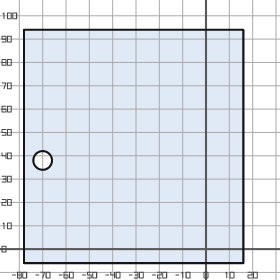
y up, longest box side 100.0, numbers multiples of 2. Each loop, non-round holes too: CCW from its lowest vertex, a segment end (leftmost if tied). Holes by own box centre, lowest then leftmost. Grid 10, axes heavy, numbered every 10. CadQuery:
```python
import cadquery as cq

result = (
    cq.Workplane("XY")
    .moveTo(-78.0, -6.0)
    .lineTo(16.0, -6.0)
    .lineTo(16.0, 94.0)
    .lineTo(-78.0, 94.0)
    .close()
    .moveTo(-70.0, 38.0)
    .circle(4.0)
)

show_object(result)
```